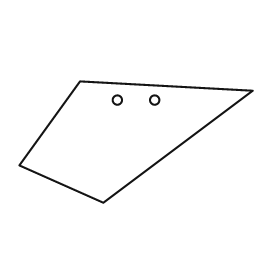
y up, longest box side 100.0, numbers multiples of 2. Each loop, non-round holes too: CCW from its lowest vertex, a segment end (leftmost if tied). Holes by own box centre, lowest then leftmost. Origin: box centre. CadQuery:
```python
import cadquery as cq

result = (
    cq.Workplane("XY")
    .moveTo(-14.0, -26.0)
    .lineTo(50.0, 22.0)
    .lineTo(-24.0, 26.0)
    .lineTo(-50.0, -10.0)
    .close()
    .moveTo(-8.0, 18.0)
    .circle(2.0)
    .moveTo(8.0, 18.0)
    .circle(2.0)
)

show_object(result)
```